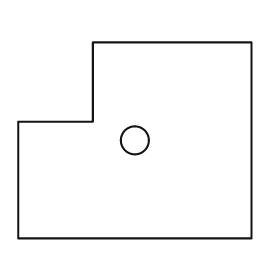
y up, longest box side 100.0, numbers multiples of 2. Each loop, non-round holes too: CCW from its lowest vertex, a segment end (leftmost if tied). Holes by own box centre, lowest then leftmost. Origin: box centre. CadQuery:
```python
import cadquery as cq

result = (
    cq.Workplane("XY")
    .moveTo(-50.0, -42.0)
    .lineTo(50.0, -42.0)
    .lineTo(50.0, 42.0)
    .lineTo(-18.0, 42.0)
    .lineTo(-18.0, 8.0)
    .lineTo(-50.0, 8.0)
    .close()
    .moveTo(0.0, 0.0)
    .circle(6.0)
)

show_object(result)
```